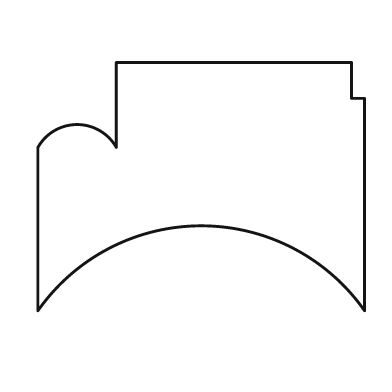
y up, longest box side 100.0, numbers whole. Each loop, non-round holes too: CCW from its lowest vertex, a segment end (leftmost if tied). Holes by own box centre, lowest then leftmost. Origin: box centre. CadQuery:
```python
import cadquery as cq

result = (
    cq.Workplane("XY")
    .moveTo(-50.0, -38.0)
    .threePointArc((0.0, -12.0), (50.0, -38.0))
    .lineTo(50.0, 27.0)
    .lineTo(46.0, 27.0)
    .lineTo(46.0, 38.0)
    .lineTo(-26.0, 38.0)
    .lineTo(-26.0, 12.0)
    .threePointArc((-38.0, 19.0), (-50.0, 12.0))
    .close()
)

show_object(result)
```